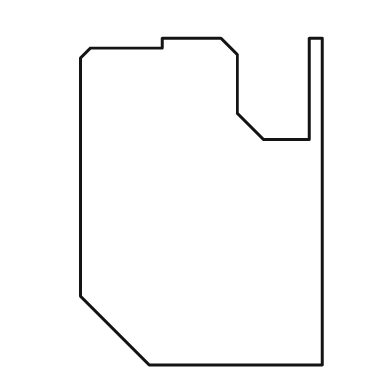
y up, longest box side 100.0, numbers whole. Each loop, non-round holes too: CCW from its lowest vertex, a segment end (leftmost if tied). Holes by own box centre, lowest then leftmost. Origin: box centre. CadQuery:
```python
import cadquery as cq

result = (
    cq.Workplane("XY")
    .moveTo(-16.0, -50.0)
    .lineTo(37.0, -50.0)
    .lineTo(37.0, 50.0)
    .lineTo(33.0, 50.0)
    .lineTo(33.0, 19.0)
    .lineTo(19.0, 19.0)
    .lineTo(11.0, 27.0)
    .lineTo(11.0, 45.0)
    .lineTo(6.0, 50.0)
    .lineTo(-12.0, 50.0)
    .lineTo(-12.0, 47.0)
    .lineTo(-34.0, 47.0)
    .lineTo(-37.0, 44.0)
    .lineTo(-37.0, -29.0)
    .close()
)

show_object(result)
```